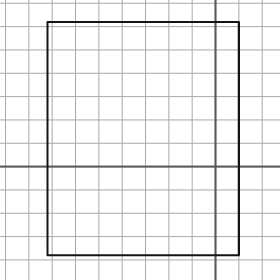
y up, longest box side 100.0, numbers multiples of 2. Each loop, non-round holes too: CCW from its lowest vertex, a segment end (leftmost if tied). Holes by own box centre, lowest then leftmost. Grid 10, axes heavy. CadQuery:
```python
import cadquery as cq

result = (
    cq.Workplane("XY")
    .moveTo(-72.0, -38.0)
    .lineTo(10.0, -38.0)
    .lineTo(10.0, 62.0)
    .lineTo(-72.0, 62.0)
    .close()
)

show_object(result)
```